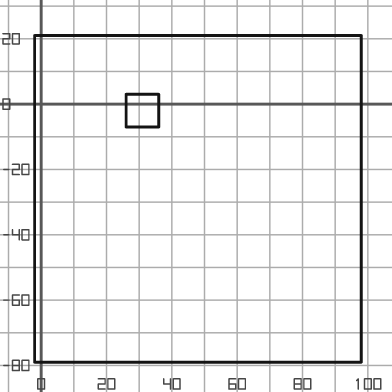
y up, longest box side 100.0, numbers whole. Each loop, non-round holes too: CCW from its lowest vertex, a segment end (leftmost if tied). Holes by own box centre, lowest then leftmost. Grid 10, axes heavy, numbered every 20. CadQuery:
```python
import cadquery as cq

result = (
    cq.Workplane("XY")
    .moveTo(-2.0, -79.0)
    .lineTo(98.0, -79.0)
    .lineTo(98.0, 21.0)
    .lineTo(-2.0, 21.0)
    .close()
    .moveTo(26.0, -7.0)
    .lineTo(36.0, -7.0)
    .lineTo(36.0, 3.0)
    .lineTo(26.0, 3.0)
    .close()
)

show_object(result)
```